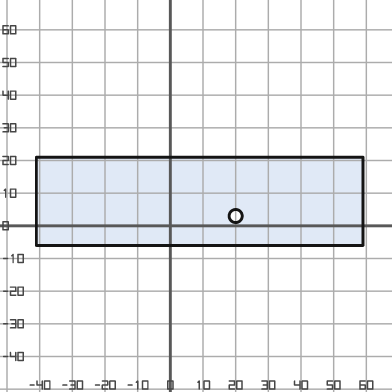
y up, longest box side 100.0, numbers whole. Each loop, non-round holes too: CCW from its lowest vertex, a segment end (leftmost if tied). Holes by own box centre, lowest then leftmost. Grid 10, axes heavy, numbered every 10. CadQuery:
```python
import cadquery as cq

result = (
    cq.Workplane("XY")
    .moveTo(-41.0, -6.0)
    .lineTo(59.0, -6.0)
    .lineTo(59.0, 21.0)
    .lineTo(-41.0, 21.0)
    .close()
    .moveTo(20.0, 3.0)
    .circle(2.0)
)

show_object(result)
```